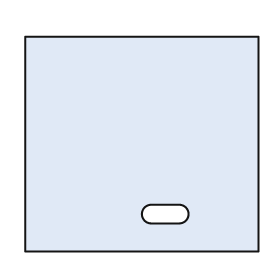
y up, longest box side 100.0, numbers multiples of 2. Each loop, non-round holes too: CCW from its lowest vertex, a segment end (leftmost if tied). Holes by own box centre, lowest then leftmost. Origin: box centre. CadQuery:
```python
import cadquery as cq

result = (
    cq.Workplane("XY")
    .moveTo(-50.0, -46.0)
    .lineTo(50.0, -46.0)
    .lineTo(50.0, 46.0)
    .lineTo(-50.0, 46.0)
    .close()
    .moveTo(4.0, -34.0)
    .lineTo(16.0, -34.0)
    .threePointArc((20.0, -30.0), (16.0, -26.0))
    .lineTo(4.0, -26.0)
    .threePointArc((0.0, -30.0), (4.0, -34.0))
    .close()
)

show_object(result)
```